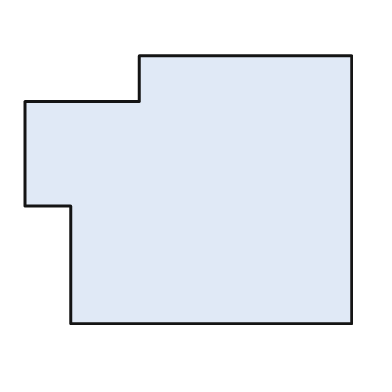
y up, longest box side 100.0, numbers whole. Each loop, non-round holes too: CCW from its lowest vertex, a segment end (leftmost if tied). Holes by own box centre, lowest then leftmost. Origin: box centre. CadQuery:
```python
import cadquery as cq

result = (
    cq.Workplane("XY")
    .moveTo(-36.0, -41.0)
    .lineTo(50.0, -41.0)
    .lineTo(50.0, 41.0)
    .lineTo(-15.0, 41.0)
    .lineTo(-15.0, 27.0)
    .lineTo(-50.0, 27.0)
    .lineTo(-50.0, -5.0)
    .lineTo(-36.0, -5.0)
    .close()
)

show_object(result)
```